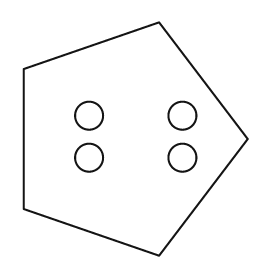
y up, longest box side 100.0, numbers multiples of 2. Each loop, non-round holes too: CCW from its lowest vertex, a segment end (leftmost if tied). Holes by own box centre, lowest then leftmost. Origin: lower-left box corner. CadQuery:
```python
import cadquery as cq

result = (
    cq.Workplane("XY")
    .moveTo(58.0, 0.0)
    .lineTo(96.0, 50.0)
    .lineTo(58.0, 100.0)
    .lineTo(0.0, 80.0)
    .lineTo(0.0, 20.0)
    .close()
    .moveTo(28.0, 42.0)
    .circle(6.0)
    .moveTo(68.0, 42.0)
    .circle(6.0)
    .moveTo(28.0, 60.0)
    .circle(6.0)
    .moveTo(68.0, 60.0)
    .circle(6.0)
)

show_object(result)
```